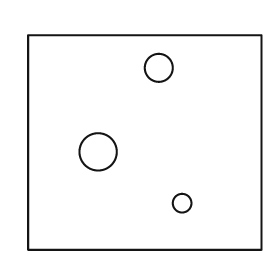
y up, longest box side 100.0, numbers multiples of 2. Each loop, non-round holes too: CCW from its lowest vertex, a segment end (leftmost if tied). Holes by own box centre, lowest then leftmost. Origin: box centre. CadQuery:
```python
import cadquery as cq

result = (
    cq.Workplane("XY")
    .moveTo(-50.0, -46.0)
    .lineTo(50.0, -46.0)
    .lineTo(50.0, 46.0)
    .lineTo(-50.0, 46.0)
    .close()
    .moveTo(16.0, -26.0)
    .circle(4.0)
    .moveTo(-20.0, -4.0)
    .circle(8.0)
    .moveTo(6.0, 32.0)
    .circle(6.0)
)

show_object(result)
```